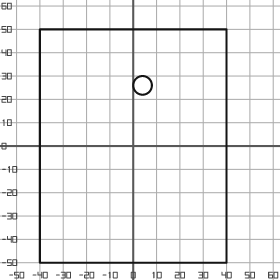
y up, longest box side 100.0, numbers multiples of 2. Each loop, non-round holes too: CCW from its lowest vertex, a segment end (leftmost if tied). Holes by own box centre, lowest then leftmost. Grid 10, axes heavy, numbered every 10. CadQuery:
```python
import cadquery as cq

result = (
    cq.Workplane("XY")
    .moveTo(-40.0, -50.0)
    .lineTo(40.0, -50.0)
    .lineTo(40.0, 50.0)
    .lineTo(-40.0, 50.0)
    .close()
    .moveTo(4.0, 26.0)
    .circle(4.0)
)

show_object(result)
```